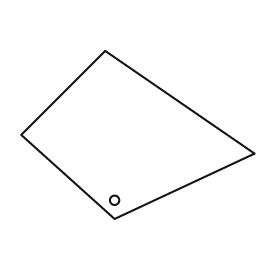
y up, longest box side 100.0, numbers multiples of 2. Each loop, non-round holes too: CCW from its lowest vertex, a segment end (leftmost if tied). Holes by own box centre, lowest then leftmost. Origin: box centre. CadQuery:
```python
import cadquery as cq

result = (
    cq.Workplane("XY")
    .moveTo(-10.0, -36.0)
    .lineTo(50.0, -8.0)
    .lineTo(-14.0, 36.0)
    .lineTo(-50.0, 0.0)
    .close()
    .moveTo(-10.0, -28.0)
    .circle(2.0)
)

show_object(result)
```